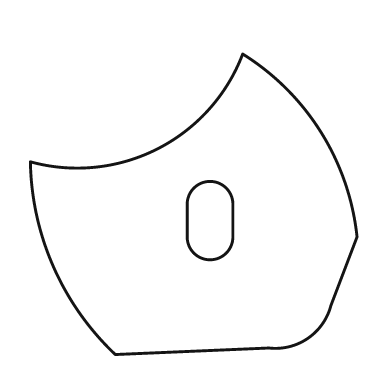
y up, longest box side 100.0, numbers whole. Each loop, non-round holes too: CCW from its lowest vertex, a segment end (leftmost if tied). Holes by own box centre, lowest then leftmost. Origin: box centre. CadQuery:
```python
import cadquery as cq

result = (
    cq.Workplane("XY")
    .moveTo(-24.0, -46.0)
    .lineTo(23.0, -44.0)
    .threePointArc((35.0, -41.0), (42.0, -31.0))
    .lineTo(50.0, -10.0)
    .threePointArc((39.0, 22.0), (15.0, 46.0))
    .threePointArc((-11.0, 17.0), (-50.0, 13.0))
    .threePointArc((-43.0, -19.0), (-24.0, -46.0))
    .close()
    .moveTo(-2.0, -10.0)
    .threePointArc((5.0, -17.0), (12.0, -10.0))
    .lineTo(12.0, 0.0)
    .threePointArc((5.0, 7.0), (-2.0, 0.0))
    .close()
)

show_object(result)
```